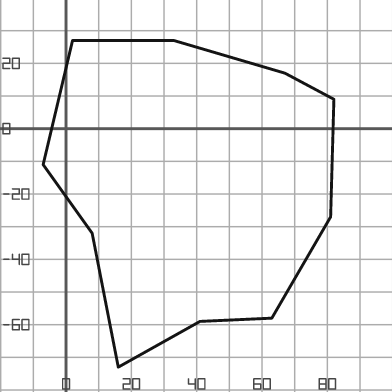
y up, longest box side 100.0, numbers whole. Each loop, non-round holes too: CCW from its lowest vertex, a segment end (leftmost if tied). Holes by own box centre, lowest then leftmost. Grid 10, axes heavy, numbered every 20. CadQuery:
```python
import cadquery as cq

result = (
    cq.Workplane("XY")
    .moveTo(16.0, -73.0)
    .lineTo(41.0, -59.0)
    .lineTo(63.0, -58.0)
    .lineTo(81.0, -27.0)
    .lineTo(82.0, 9.0)
    .lineTo(67.0, 17.0)
    .lineTo(33.0, 27.0)
    .lineTo(2.0, 27.0)
    .lineTo(-7.0, -11.0)
    .lineTo(8.0, -32.0)
    .close()
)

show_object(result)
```